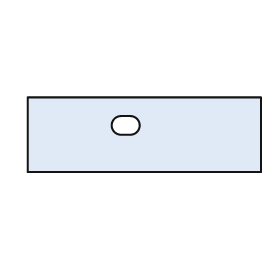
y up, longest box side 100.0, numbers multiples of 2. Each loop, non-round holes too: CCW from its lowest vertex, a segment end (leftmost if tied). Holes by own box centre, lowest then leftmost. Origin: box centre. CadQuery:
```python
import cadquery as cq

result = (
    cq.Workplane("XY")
    .moveTo(-50.0, -16.0)
    .lineTo(50.0, -16.0)
    .lineTo(50.0, 16.0)
    .lineTo(-50.0, 16.0)
    .close()
    .moveTo(-10.0, 0.0)
    .lineTo(-6.0, 0.0)
    .threePointArc((-2.0, 4.0), (-6.0, 8.0))
    .lineTo(-10.0, 8.0)
    .threePointArc((-14.0, 4.0), (-10.0, 0.0))
    .close()
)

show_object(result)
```